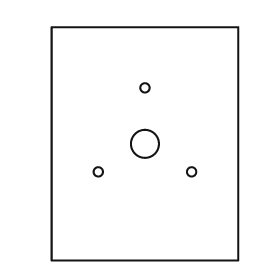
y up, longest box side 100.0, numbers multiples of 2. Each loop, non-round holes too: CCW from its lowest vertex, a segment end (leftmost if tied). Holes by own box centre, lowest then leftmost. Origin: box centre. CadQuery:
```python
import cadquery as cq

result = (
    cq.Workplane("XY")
    .moveTo(-40.0, -50.0)
    .lineTo(40.0, -50.0)
    .lineTo(40.0, 50.0)
    .lineTo(-40.0, 50.0)
    .close()
    .moveTo(-20.0, -12.0)
    .circle(2.0)
    .moveTo(20.0, -12.0)
    .circle(2.0)
    .moveTo(0.0, 0.0)
    .circle(6.0)
    .moveTo(0.0, 24.0)
    .circle(2.0)
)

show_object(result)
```